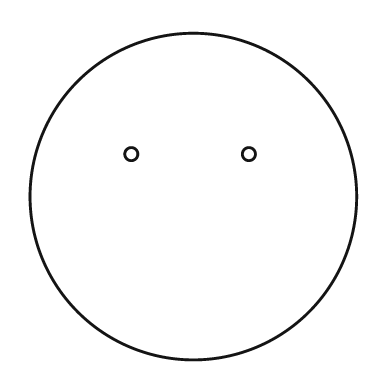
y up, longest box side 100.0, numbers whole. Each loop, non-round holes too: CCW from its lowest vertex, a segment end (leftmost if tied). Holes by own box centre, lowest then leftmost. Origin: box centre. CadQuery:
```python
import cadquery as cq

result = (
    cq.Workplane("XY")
    .moveTo(0.0, 0.0)
    .circle(50.0)
    .moveTo(-19.0, 13.0)
    .circle(2.0)
    .moveTo(17.0, 13.0)
    .circle(2.0)
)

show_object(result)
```